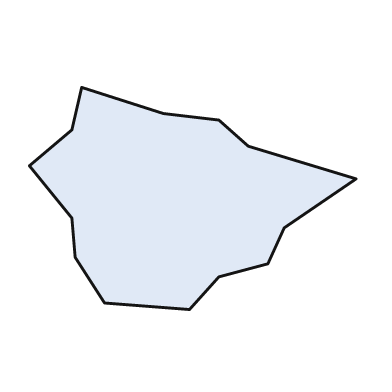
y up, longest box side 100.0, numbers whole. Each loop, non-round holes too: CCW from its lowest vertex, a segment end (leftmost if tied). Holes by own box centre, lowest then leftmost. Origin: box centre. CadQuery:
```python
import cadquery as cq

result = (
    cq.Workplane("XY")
    .moveTo(-1.0, -34.0)
    .lineTo(8.0, -24.0)
    .lineTo(23.0, -20.0)
    .lineTo(28.0, -9.0)
    .lineTo(50.0, 6.0)
    .lineTo(17.0, 16.0)
    .lineTo(8.0, 24.0)
    .lineTo(-9.0, 26.0)
    .lineTo(-34.0, 34.0)
    .lineTo(-37.0, 21.0)
    .lineTo(-50.0, 10.0)
    .lineTo(-37.0, -6.0)
    .lineTo(-36.0, -18.0)
    .lineTo(-27.0, -32.0)
    .close()
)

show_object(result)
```